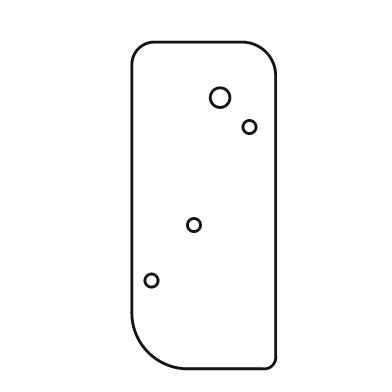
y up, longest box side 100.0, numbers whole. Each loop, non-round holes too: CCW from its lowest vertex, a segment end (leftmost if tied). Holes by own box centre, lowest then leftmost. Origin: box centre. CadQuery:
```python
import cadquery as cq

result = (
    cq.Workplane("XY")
    .moveTo(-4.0, -50.0)
    .lineTo(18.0, -50.0)
    .threePointArc((21.0, -49.0), (22.0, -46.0))
    .lineTo(22.0, 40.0)
    .threePointArc((19.0, 47.0), (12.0, 50.0))
    .lineTo(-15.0, 50.0)
    .threePointArc((-20.0, 48.0), (-22.0, 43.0))
    .lineTo(-22.0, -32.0)
    .threePointArc((-17.0, -45.0), (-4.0, -50.0))
    .close()
    .moveTo(-16.0, -23.0)
    .circle(2.0)
    .moveTo(-3.0, -6.0)
    .circle(2.0)
    .moveTo(14.0, 24.0)
    .circle(2.0)
    .moveTo(5.0, 33.0)
    .circle(3.0)
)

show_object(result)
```